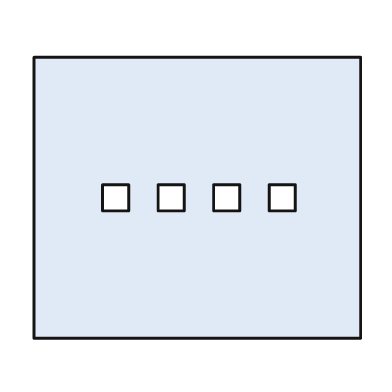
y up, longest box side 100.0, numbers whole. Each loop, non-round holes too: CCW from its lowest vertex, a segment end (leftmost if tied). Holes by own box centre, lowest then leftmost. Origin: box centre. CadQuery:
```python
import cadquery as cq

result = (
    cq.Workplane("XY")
    .moveTo(-50.0, -43.0)
    .lineTo(50.0, -43.0)
    .lineTo(50.0, 43.0)
    .lineTo(-50.0, 43.0)
    .close()
    .moveTo(-29.0, -4.0)
    .lineTo(-21.0, -4.0)
    .lineTo(-21.0, 4.0)
    .lineTo(-29.0, 4.0)
    .close()
    .moveTo(-12.0, -4.0)
    .lineTo(-4.0, -4.0)
    .lineTo(-4.0, 4.0)
    .lineTo(-12.0, 4.0)
    .close()
    .moveTo(5.0, -4.0)
    .lineTo(13.0, -4.0)
    .lineTo(13.0, 4.0)
    .lineTo(5.0, 4.0)
    .close()
    .moveTo(22.0, -4.0)
    .lineTo(30.0, -4.0)
    .lineTo(30.0, 4.0)
    .lineTo(22.0, 4.0)
    .close()
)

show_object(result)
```